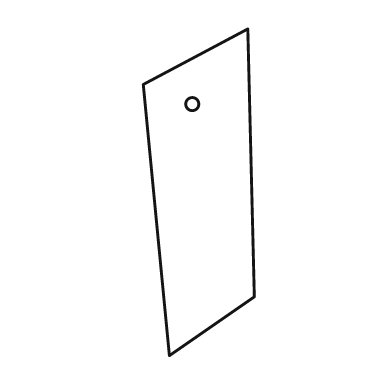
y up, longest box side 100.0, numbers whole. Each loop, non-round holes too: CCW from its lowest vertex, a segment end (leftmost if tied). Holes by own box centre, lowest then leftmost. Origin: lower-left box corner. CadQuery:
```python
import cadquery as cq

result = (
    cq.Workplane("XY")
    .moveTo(8.0, 0.0)
    .lineTo(34.0, 18.0)
    .lineTo(32.0, 100.0)
    .lineTo(0.0, 83.0)
    .close()
    .moveTo(15.0, 77.0)
    .circle(2.0)
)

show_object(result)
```